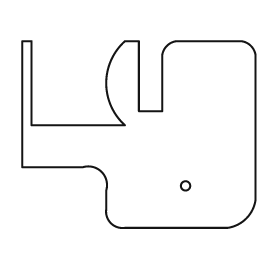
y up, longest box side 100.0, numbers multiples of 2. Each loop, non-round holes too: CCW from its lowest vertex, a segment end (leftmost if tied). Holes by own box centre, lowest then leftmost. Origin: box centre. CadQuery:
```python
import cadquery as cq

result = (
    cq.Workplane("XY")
    .moveTo(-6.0, -40.0)
    .lineTo(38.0, -40.0)
    .threePointArc((46.0, -36.0), (50.0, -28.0))
    .lineTo(50.0, 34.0)
    .threePointArc((48.0, 38.0), (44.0, 40.0))
    .lineTo(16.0, 40.0)
    .threePointArc((12.0, 38.0), (10.0, 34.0))
    .lineTo(10.0, 10.0)
    .lineTo(0.0, 10.0)
    .lineTo(0.0, 40.0)
    .lineTo(-6.0, 40.0)
    .threePointArc((-14.0, 22.0), (-6.0, 4.0))
    .lineTo(-46.0, 4.0)
    .lineTo(-46.0, 40.0)
    .lineTo(-50.0, 40.0)
    .lineTo(-50.0, -14.0)
    .lineTo(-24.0, -14.0)
    .threePointArc((-16.0, -16.0), (-14.0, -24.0))
    .lineTo(-14.0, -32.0)
    .threePointArc((-12.0, -38.0), (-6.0, -40.0))
    .close()
    .moveTo(20.0, -22.0)
    .circle(2.0)
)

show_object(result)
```